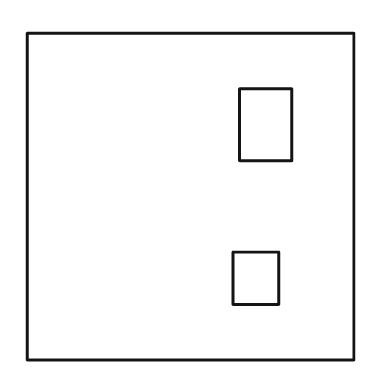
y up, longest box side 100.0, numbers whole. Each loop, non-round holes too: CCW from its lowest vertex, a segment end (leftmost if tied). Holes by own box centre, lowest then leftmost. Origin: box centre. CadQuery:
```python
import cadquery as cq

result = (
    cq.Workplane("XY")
    .moveTo(-50.0, -50.0)
    .lineTo(50.0, -50.0)
    .lineTo(50.0, 50.0)
    .lineTo(-50.0, 50.0)
    .close()
    .moveTo(13.0, -33.0)
    .lineTo(27.0, -33.0)
    .lineTo(27.0, -17.0)
    .lineTo(13.0, -17.0)
    .close()
    .moveTo(15.0, 11.0)
    .lineTo(31.0, 11.0)
    .lineTo(31.0, 33.0)
    .lineTo(15.0, 33.0)
    .close()
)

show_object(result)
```